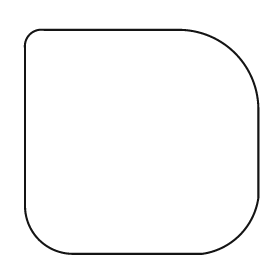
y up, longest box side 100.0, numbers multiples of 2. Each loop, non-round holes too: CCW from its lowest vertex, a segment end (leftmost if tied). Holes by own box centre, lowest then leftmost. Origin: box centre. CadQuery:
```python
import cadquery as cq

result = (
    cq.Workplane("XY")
    .moveTo(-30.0, -48.0)
    .lineTo(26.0, -48.0)
    .threePointArc((42.0, -40.0), (50.0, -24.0))
    .lineTo(50.0, 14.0)
    .threePointArc((40.0, 38.0), (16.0, 48.0))
    .lineTo(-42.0, 48.0)
    .threePointArc((-48.0, 46.0), (-50.0, 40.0))
    .lineTo(-50.0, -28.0)
    .threePointArc((-44.0, -42.0), (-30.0, -48.0))
    .close()
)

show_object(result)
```